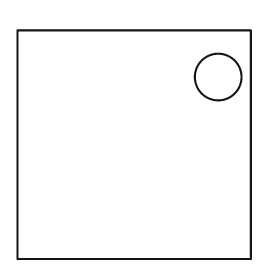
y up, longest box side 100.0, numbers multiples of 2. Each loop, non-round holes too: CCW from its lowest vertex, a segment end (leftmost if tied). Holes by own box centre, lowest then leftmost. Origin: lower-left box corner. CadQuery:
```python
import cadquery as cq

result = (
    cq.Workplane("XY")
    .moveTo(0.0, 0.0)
    .lineTo(100.0, 0.0)
    .lineTo(100.0, 98.0)
    .lineTo(0.0, 98.0)
    .close()
    .moveTo(86.0, 78.0)
    .circle(10.0)
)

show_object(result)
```